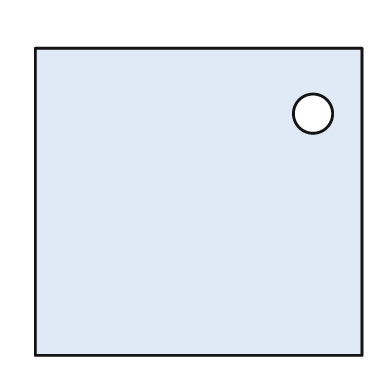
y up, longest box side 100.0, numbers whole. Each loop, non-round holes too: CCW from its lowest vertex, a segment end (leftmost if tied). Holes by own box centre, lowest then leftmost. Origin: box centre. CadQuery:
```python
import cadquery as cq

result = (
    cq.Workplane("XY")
    .moveTo(-50.0, -47.0)
    .lineTo(50.0, -47.0)
    .lineTo(50.0, 47.0)
    .lineTo(-50.0, 47.0)
    .close()
    .moveTo(35.0, 27.0)
    .circle(6.0)
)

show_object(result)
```